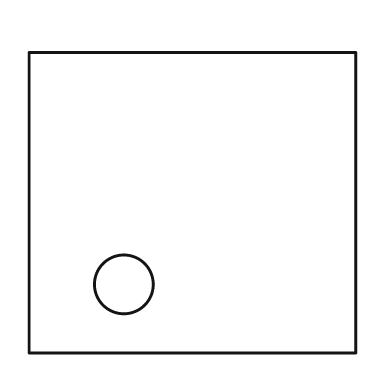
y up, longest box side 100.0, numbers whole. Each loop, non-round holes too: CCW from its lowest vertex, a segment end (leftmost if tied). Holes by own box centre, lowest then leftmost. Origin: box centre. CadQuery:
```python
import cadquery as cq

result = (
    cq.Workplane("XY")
    .moveTo(-50.0, -46.0)
    .lineTo(50.0, -46.0)
    .lineTo(50.0, 46.0)
    .lineTo(-50.0, 46.0)
    .close()
    .moveTo(-21.0, -25.0)
    .circle(9.0)
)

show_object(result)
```